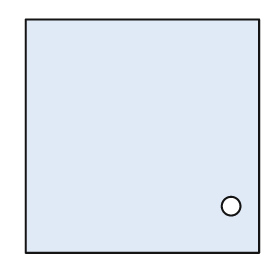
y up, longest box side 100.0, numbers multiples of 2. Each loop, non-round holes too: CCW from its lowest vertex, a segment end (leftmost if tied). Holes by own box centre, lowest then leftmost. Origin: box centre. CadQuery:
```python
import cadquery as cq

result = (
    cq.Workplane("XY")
    .moveTo(-50.0, -50.0)
    .lineTo(50.0, -50.0)
    .lineTo(50.0, 50.0)
    .lineTo(-50.0, 50.0)
    .close()
    .moveTo(38.0, -30.0)
    .circle(4.0)
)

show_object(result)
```